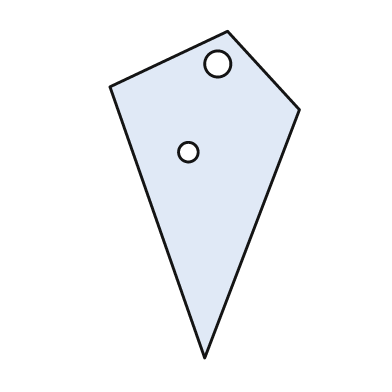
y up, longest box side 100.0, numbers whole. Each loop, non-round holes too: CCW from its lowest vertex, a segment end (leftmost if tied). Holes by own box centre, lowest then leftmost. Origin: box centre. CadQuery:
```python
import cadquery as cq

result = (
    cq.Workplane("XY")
    .moveTo(0.0, -50.0)
    .lineTo(29.0, 26.0)
    .lineTo(7.0, 50.0)
    .lineTo(-29.0, 33.0)
    .close()
    .moveTo(-5.0, 13.0)
    .circle(3.0)
    .moveTo(4.0, 40.0)
    .circle(4.0)
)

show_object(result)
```